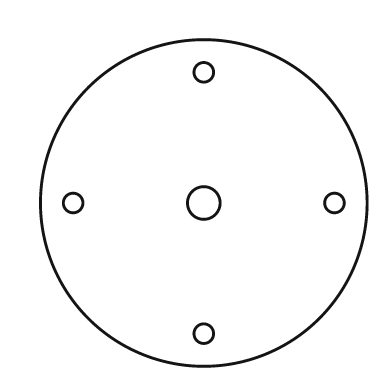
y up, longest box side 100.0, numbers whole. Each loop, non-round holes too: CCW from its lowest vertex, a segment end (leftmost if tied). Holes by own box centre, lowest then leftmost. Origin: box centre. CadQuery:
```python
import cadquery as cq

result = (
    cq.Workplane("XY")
    .moveTo(0.0, 0.0)
    .circle(50.0)
    .moveTo(0.0, -40.0)
    .circle(3.0)
    .moveTo(-40.0, 0.0)
    .circle(3.0)
    .moveTo(0.0, 0.0)
    .circle(5.0)
    .moveTo(40.0, 0.0)
    .circle(3.0)
    .moveTo(0.0, 40.0)
    .circle(3.0)
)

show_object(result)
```